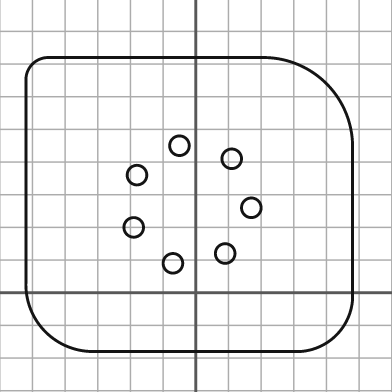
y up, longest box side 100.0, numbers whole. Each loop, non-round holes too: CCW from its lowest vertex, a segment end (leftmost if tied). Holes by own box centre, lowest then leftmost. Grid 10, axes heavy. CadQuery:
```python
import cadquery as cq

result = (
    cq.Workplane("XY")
    .moveTo(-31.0, -18.0)
    .lineTo(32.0, -18.0)
    .threePointArc((43.0, -13.0), (48.0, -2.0))
    .lineTo(48.0, 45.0)
    .threePointArc((40.0, 64.0), (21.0, 72.0))
    .lineTo(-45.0, 72.0)
    .threePointArc((-50.0, 70.0), (-52.0, 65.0))
    .lineTo(-52.0, 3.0)
    .threePointArc((-46.0, -12.0), (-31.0, -18.0))
    .close()
    .moveTo(-7.0, 9.0)
    .circle(3.0)
    .moveTo(9.0, 12.0)
    .circle(3.0)
    .moveTo(-19.0, 20.0)
    .circle(3.0)
    .moveTo(17.0, 26.0)
    .circle(3.0)
    .moveTo(-18.0, 36.0)
    .circle(3.0)
    .moveTo(11.0, 41.0)
    .circle(3.0)
    .moveTo(-5.0, 45.0)
    .circle(3.0)
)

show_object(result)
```